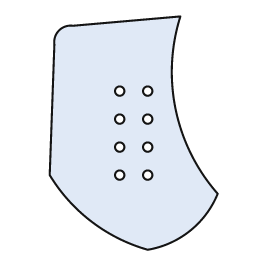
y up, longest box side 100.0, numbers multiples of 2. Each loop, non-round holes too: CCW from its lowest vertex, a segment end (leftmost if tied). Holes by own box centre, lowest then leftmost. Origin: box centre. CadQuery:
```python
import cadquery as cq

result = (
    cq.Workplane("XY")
    .moveTo(6.0, -50.0)
    .threePointArc((24.0, -42.0), (36.0, -26.0))
    .threePointArc((18.0, 10.0), (20.0, 50.0))
    .lineTo(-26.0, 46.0)
    .threePointArc((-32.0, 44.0), (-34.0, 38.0))
    .lineTo(-36.0, -18.0)
    .threePointArc((-18.0, -38.0), (6.0, -50.0))
    .close()
    .moveTo(-6.0, -18.0)
    .circle(2.0)
    .moveTo(6.0, -18.0)
    .circle(2.0)
    .moveTo(-6.0, -6.0)
    .circle(2.0)
    .moveTo(6.0, -6.0)
    .circle(2.0)
    .moveTo(-6.0, 6.0)
    .circle(2.0)
    .moveTo(6.0, 6.0)
    .circle(2.0)
    .moveTo(-6.0, 18.0)
    .circle(2.0)
    .moveTo(6.0, 18.0)
    .circle(2.0)
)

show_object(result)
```